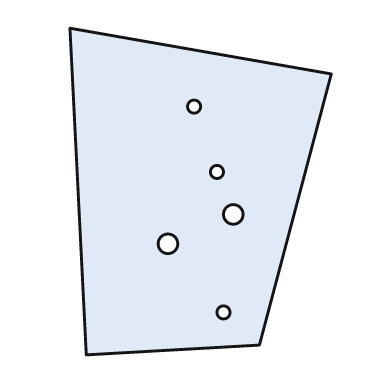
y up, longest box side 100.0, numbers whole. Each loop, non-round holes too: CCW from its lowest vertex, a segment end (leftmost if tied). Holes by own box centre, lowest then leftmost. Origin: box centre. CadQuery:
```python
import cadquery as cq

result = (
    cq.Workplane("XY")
    .moveTo(-35.0, -50.0)
    .lineTo(18.0, -47.0)
    .lineTo(40.0, 36.0)
    .lineTo(-40.0, 50.0)
    .close()
    .moveTo(7.0, -37.0)
    .circle(2.0)
    .moveTo(-10.0, -16.0)
    .circle(3.0)
    .moveTo(10.0, -7.0)
    .circle(3.0)
    .moveTo(5.0, 6.0)
    .circle(2.0)
    .moveTo(-2.0, 26.0)
    .circle(2.0)
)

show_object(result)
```